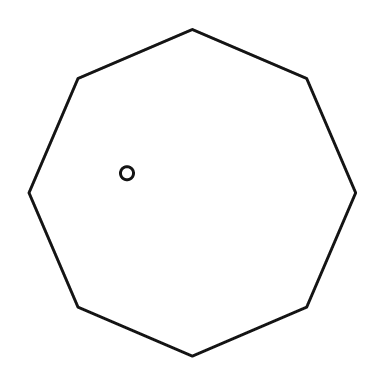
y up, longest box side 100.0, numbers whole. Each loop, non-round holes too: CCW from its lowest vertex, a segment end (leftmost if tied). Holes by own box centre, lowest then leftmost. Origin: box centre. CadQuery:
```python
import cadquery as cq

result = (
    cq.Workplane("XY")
    .moveTo(0.0, -50.0)
    .lineTo(35.0, -35.0)
    .lineTo(50.0, 0.0)
    .lineTo(35.0, 35.0)
    .lineTo(0.0, 50.0)
    .lineTo(-35.0, 35.0)
    .lineTo(-50.0, 0.0)
    .lineTo(-35.0, -35.0)
    .close()
    .moveTo(-20.0, 6.0)
    .circle(2.0)
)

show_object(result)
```